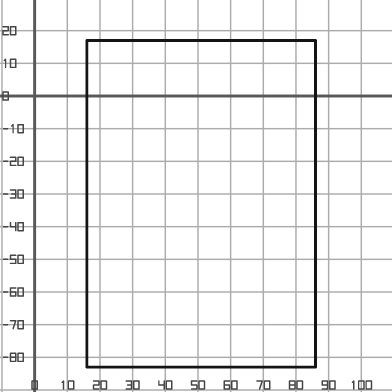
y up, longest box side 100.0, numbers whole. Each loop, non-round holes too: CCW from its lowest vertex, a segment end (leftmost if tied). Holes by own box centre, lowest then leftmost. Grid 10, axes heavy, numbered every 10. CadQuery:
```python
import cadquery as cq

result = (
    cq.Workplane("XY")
    .moveTo(16.0, -83.0)
    .lineTo(86.0, -83.0)
    .lineTo(86.0, 17.0)
    .lineTo(16.0, 17.0)
    .close()
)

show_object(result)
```